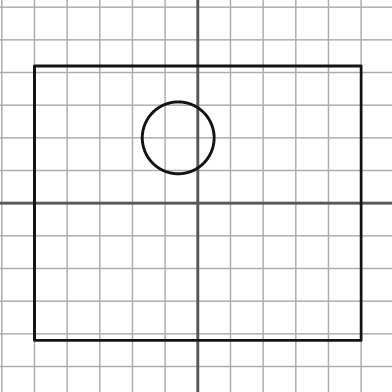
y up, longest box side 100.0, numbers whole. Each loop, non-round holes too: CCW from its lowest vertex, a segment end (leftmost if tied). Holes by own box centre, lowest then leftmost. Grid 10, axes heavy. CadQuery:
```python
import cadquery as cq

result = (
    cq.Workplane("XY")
    .moveTo(-50.0, -42.0)
    .lineTo(50.0, -42.0)
    .lineTo(50.0, 42.0)
    .lineTo(-50.0, 42.0)
    .close()
    .moveTo(-6.0, 20.0)
    .circle(11.0)
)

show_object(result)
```